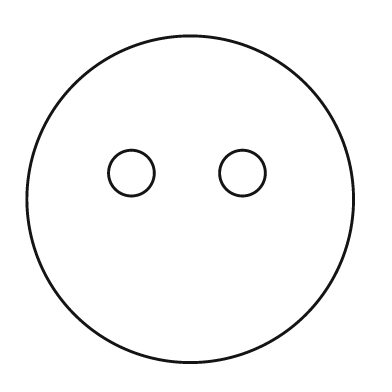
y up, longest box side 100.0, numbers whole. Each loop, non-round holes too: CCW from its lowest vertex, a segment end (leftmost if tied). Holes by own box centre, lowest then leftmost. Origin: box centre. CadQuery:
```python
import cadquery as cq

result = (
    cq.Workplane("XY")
    .moveTo(0.0, 0.0)
    .circle(50.0)
    .moveTo(-18.0, 8.0)
    .circle(7.0)
    .moveTo(16.0, 8.0)
    .circle(7.0)
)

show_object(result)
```